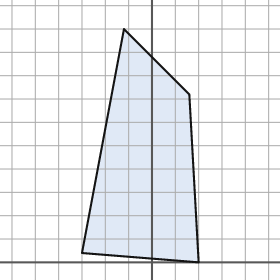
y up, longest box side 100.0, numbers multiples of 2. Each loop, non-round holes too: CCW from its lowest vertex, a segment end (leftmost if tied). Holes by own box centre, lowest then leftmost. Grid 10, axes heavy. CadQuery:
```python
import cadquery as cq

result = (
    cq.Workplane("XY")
    .moveTo(20.0, 0.0)
    .lineTo(16.0, 72.0)
    .lineTo(-12.0, 100.0)
    .lineTo(-30.0, 4.0)
    .close()
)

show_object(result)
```